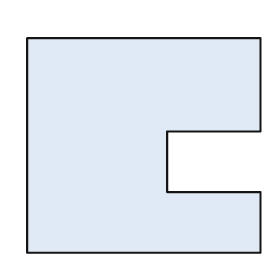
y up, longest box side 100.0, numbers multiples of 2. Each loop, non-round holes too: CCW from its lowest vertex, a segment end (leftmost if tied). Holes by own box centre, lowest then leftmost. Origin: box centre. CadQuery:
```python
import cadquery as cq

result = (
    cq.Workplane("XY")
    .moveTo(-50.0, -46.0)
    .lineTo(50.0, -46.0)
    .lineTo(50.0, -20.0)
    .lineTo(10.0, -20.0)
    .lineTo(10.0, 6.0)
    .lineTo(50.0, 6.0)
    .lineTo(50.0, 46.0)
    .lineTo(-50.0, 46.0)
    .close()
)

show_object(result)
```